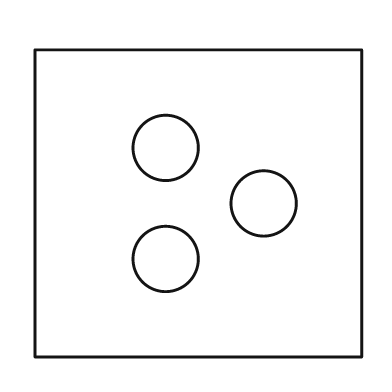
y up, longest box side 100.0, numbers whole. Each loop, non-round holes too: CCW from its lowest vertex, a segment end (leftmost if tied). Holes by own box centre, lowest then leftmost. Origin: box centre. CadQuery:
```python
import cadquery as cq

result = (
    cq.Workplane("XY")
    .moveTo(-50.0, -47.0)
    .lineTo(50.0, -47.0)
    .lineTo(50.0, 47.0)
    .lineTo(-50.0, 47.0)
    .close()
    .moveTo(-10.0, -17.0)
    .circle(10.0)
    .moveTo(20.0, 0.0)
    .circle(10.0)
    .moveTo(-10.0, 17.0)
    .circle(10.0)
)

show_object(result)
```